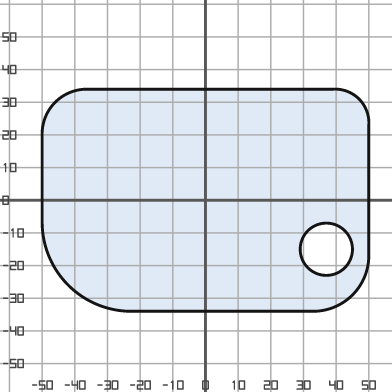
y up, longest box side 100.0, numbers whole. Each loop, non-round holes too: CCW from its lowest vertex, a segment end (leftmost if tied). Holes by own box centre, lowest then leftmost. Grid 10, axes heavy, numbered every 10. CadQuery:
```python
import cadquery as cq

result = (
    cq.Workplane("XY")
    .moveTo(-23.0, -34.0)
    .lineTo(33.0, -34.0)
    .threePointArc((45.0, -29.0), (50.0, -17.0))
    .lineTo(50.0, 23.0)
    .threePointArc((47.0, 31.0), (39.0, 34.0))
    .lineTo(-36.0, 34.0)
    .threePointArc((-46.0, 30.0), (-50.0, 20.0))
    .lineTo(-50.0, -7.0)
    .threePointArc((-42.0, -26.0), (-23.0, -34.0))
    .close()
    .moveTo(37.0, -15.0)
    .circle(8.0)
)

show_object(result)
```